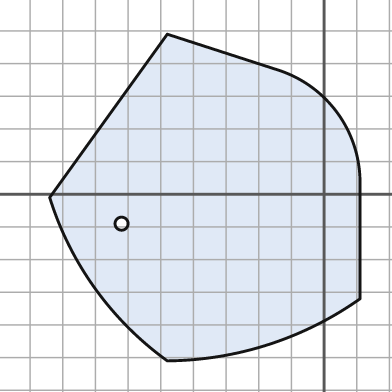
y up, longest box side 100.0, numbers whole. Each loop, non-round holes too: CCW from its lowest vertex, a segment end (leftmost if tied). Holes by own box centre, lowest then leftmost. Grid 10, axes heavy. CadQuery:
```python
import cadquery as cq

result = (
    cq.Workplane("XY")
    .moveTo(-48.0, -51.0)
    .threePointArc((-17.0, -46.0), (11.0, -32.0))
    .lineTo(11.0, 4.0)
    .threePointArc((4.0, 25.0), (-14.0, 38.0))
    .lineTo(-48.0, 49.0)
    .lineTo(-84.0, -1.0)
    .threePointArc((-70.0, -29.0), (-48.0, -51.0))
    .close()
    .moveTo(-62.0, -9.0)
    .circle(2.0)
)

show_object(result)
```